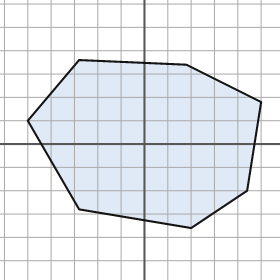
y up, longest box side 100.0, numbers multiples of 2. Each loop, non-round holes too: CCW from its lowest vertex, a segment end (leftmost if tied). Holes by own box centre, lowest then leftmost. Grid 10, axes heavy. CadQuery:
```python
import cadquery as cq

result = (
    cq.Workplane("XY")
    .moveTo(20.0, -36.0)
    .lineTo(44.0, -20.0)
    .lineTo(50.0, 18.0)
    .lineTo(18.0, 34.0)
    .lineTo(-28.0, 36.0)
    .lineTo(-50.0, 10.0)
    .lineTo(-28.0, -28.0)
    .close()
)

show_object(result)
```